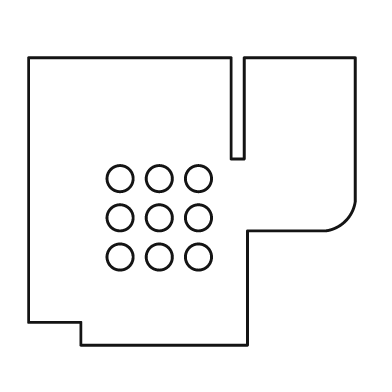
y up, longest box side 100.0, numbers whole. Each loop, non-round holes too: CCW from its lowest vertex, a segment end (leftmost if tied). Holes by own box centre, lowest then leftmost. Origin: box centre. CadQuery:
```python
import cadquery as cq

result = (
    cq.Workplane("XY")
    .moveTo(-34.0, -44.0)
    .lineTo(17.0, -44.0)
    .lineTo(17.0, -9.0)
    .lineTo(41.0, -9.0)
    .threePointArc((47.0, -6.0), (50.0, 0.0))
    .lineTo(50.0, 44.0)
    .lineTo(16.0, 44.0)
    .lineTo(16.0, 13.0)
    .lineTo(12.0, 13.0)
    .lineTo(12.0, 44.0)
    .lineTo(-50.0, 44.0)
    .lineTo(-50.0, -37.0)
    .lineTo(-34.0, -37.0)
    .close()
    .moveTo(-22.0, -17.0)
    .circle(4.0)
    .moveTo(-10.0, -17.0)
    .circle(4.0)
    .moveTo(2.0, -17.0)
    .circle(4.0)
    .moveTo(-22.0, -5.0)
    .circle(4.0)
    .moveTo(-10.0, -5.0)
    .circle(4.0)
    .moveTo(2.0, -5.0)
    .circle(4.0)
    .moveTo(-22.0, 7.0)
    .circle(4.0)
    .moveTo(-10.0, 7.0)
    .circle(4.0)
    .moveTo(2.0, 7.0)
    .circle(4.0)
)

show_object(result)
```